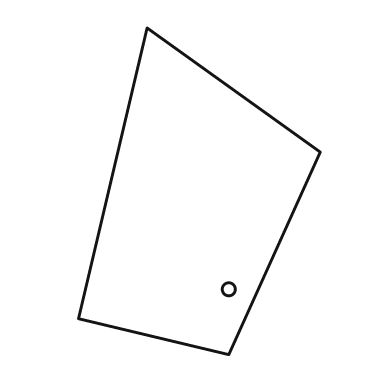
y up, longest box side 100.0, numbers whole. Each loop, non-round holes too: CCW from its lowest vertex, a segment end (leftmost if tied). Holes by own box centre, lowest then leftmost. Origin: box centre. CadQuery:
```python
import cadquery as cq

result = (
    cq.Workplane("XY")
    .moveTo(9.0, -50.0)
    .lineTo(37.0, 12.0)
    .lineTo(-16.0, 50.0)
    .lineTo(-37.0, -39.0)
    .close()
    .moveTo(9.0, -30.0)
    .circle(2.0)
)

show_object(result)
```